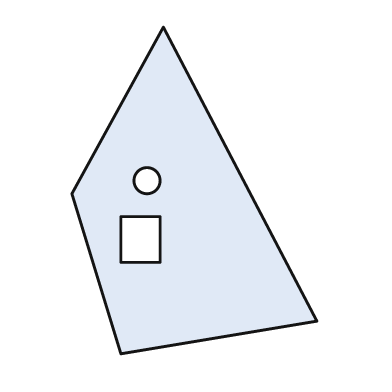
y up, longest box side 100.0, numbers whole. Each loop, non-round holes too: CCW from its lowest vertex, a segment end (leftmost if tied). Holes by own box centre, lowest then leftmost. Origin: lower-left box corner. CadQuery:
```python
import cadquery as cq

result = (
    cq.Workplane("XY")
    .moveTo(15.0, 0.0)
    .lineTo(75.0, 10.0)
    .lineTo(28.0, 100.0)
    .lineTo(0.0, 49.0)
    .close()
    .moveTo(15.0, 28.0)
    .lineTo(27.0, 28.0)
    .lineTo(27.0, 42.0)
    .lineTo(15.0, 42.0)
    .close()
    .moveTo(23.0, 53.0)
    .circle(4.0)
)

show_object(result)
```